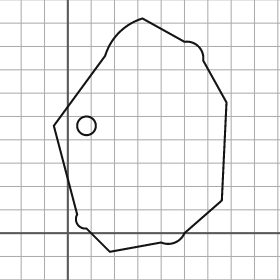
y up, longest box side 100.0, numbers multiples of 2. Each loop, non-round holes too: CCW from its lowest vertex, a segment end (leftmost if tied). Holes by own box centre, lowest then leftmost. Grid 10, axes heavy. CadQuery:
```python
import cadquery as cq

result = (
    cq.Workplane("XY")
    .moveTo(18.0, -8.0)
    .lineTo(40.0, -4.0)
    .threePointArc((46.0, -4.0), (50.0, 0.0))
    .lineTo(66.0, 14.0)
    .lineTo(68.0, 56.0)
    .lineTo(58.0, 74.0)
    .threePointArc((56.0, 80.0), (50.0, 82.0))
    .lineTo(32.0, 92.0)
    .threePointArc((22.0, 86.0), (16.0, 76.0))
    .lineTo(-6.0, 46.0)
    .lineTo(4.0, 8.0)
    .threePointArc((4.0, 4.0), (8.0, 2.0))
    .close()
    .moveTo(8.0, 46.0)
    .circle(4.0)
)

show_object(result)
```